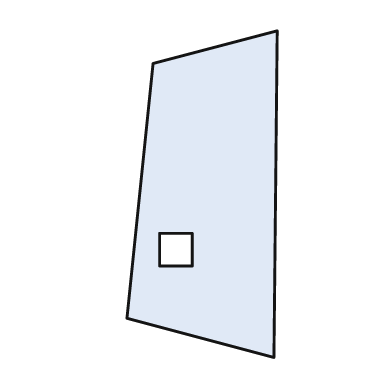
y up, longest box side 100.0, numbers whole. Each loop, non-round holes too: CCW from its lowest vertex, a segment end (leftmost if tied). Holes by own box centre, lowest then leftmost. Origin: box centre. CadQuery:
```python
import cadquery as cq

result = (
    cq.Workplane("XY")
    .moveTo(22.0, -50.0)
    .lineTo(23.0, 50.0)
    .lineTo(-15.0, 40.0)
    .lineTo(-23.0, -38.0)
    .close()
    .moveTo(-13.0, -22.0)
    .lineTo(-3.0, -22.0)
    .lineTo(-3.0, -12.0)
    .lineTo(-13.0, -12.0)
    .close()
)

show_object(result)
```